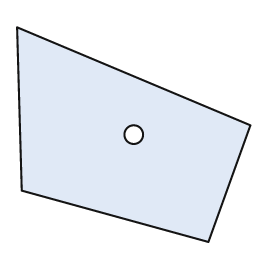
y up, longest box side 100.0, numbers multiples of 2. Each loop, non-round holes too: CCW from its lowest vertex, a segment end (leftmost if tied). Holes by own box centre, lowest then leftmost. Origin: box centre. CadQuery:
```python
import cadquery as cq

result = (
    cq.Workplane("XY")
    .moveTo(32.0, -46.0)
    .lineTo(50.0, 4.0)
    .lineTo(-50.0, 46.0)
    .lineTo(-48.0, -24.0)
    .close()
    .moveTo(0.0, 0.0)
    .circle(4.0)
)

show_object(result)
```